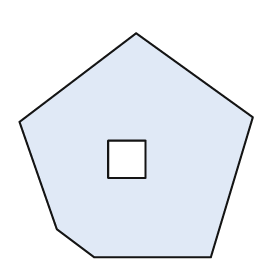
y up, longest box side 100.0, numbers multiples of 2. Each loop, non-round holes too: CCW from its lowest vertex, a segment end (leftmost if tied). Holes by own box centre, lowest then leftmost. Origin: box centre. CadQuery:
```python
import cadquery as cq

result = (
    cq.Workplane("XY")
    .moveTo(-18.0, -48.0)
    .lineTo(32.0, -48.0)
    .lineTo(50.0, 12.0)
    .lineTo(0.0, 48.0)
    .lineTo(-50.0, 10.0)
    .lineTo(-34.0, -36.0)
    .close()
    .moveTo(-12.0, -14.0)
    .lineTo(4.0, -14.0)
    .lineTo(4.0, 2.0)
    .lineTo(-12.0, 2.0)
    .close()
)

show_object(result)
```